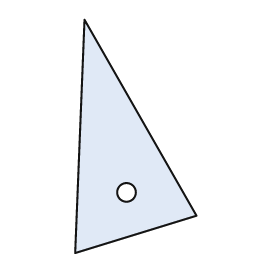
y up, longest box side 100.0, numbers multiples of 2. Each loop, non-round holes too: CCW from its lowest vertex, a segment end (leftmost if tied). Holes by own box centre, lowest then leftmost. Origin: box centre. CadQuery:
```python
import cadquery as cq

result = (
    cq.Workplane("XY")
    .moveTo(-26.0, -50.0)
    .lineTo(26.0, -34.0)
    .lineTo(-22.0, 50.0)
    .close()
    .moveTo(-4.0, -24.0)
    .circle(4.0)
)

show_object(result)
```